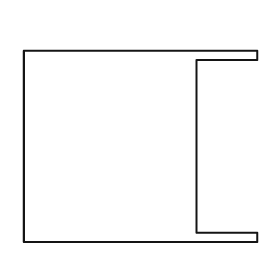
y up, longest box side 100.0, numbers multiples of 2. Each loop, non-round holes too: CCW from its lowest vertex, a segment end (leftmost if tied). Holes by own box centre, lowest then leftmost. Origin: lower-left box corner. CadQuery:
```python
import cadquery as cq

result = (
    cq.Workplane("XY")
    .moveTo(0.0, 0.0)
    .lineTo(100.0, 0.0)
    .lineTo(100.0, 4.0)
    .lineTo(74.0, 4.0)
    .lineTo(74.0, 78.0)
    .lineTo(100.0, 78.0)
    .lineTo(100.0, 82.0)
    .lineTo(0.0, 82.0)
    .close()
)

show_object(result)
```